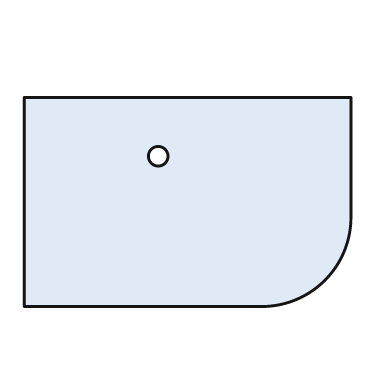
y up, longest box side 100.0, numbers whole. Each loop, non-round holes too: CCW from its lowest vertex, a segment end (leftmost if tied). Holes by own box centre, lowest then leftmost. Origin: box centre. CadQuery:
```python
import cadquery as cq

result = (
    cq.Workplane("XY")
    .moveTo(-50.0, -32.0)
    .lineTo(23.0, -32.0)
    .threePointArc((42.0, -24.0), (50.0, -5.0))
    .lineTo(50.0, 32.0)
    .lineTo(-50.0, 32.0)
    .close()
    .moveTo(-9.0, 14.0)
    .circle(3.0)
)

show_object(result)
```